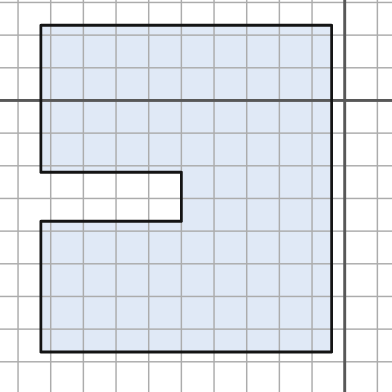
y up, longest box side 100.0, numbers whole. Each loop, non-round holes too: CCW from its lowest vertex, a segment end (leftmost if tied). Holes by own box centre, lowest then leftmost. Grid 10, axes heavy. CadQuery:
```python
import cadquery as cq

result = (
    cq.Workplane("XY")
    .moveTo(-93.0, -77.0)
    .lineTo(-4.0, -77.0)
    .lineTo(-4.0, 23.0)
    .lineTo(-93.0, 23.0)
    .lineTo(-93.0, -22.0)
    .lineTo(-50.0, -22.0)
    .lineTo(-50.0, -37.0)
    .lineTo(-93.0, -37.0)
    .close()
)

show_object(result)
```